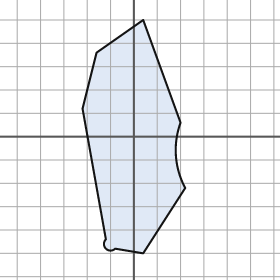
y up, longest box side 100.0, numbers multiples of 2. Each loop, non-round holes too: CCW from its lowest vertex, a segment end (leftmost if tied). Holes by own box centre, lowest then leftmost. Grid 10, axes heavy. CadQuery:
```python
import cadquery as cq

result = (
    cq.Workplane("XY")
    .moveTo(4.0, -50.0)
    .lineTo(22.0, -22.0)
    .threePointArc((18.0, -8.0), (20.0, 6.0))
    .lineTo(4.0, 50.0)
    .lineTo(-16.0, 36.0)
    .lineTo(-22.0, 12.0)
    .lineTo(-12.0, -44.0)
    .threePointArc((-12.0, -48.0), (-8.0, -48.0))
    .close()
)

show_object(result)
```